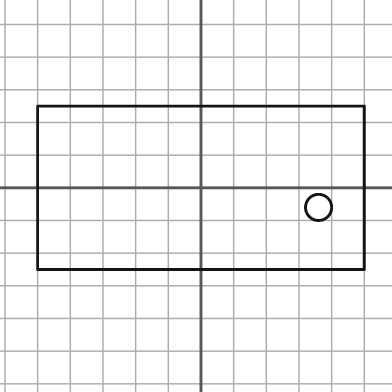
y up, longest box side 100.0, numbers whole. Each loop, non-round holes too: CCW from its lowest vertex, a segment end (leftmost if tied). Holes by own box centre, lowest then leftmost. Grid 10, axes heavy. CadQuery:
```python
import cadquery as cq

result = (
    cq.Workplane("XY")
    .moveTo(-50.0, -25.0)
    .lineTo(50.0, -25.0)
    .lineTo(50.0, 25.0)
    .lineTo(-50.0, 25.0)
    .close()
    .moveTo(36.0, -6.0)
    .circle(4.0)
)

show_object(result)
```